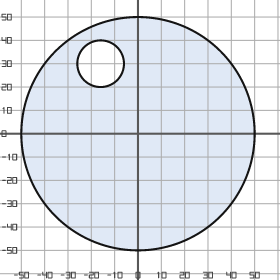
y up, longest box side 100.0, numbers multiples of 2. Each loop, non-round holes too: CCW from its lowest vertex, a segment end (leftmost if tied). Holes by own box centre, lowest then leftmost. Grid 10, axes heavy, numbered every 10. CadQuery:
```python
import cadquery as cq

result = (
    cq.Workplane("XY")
    .moveTo(0.0, 0.0)
    .circle(50.0)
    .moveTo(-16.0, 30.0)
    .circle(10.0)
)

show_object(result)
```